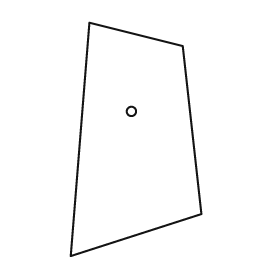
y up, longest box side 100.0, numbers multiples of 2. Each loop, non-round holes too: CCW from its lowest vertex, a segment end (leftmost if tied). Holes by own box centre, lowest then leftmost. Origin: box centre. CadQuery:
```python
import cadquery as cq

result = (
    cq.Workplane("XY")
    .moveTo(-28.0, -50.0)
    .lineTo(28.0, -32.0)
    .lineTo(20.0, 40.0)
    .lineTo(-20.0, 50.0)
    .close()
    .moveTo(-2.0, 12.0)
    .circle(2.0)
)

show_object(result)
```